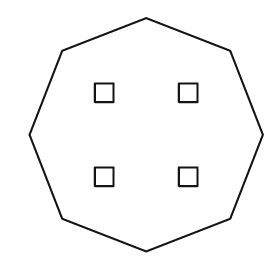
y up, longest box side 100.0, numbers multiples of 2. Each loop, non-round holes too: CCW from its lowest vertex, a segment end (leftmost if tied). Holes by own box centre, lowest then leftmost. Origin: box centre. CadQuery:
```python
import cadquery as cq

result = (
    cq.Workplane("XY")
    .moveTo(0.0, -50.0)
    .lineTo(36.0, -36.0)
    .lineTo(50.0, 0.0)
    .lineTo(36.0, 36.0)
    .lineTo(0.0, 50.0)
    .lineTo(-36.0, 36.0)
    .lineTo(-50.0, 0.0)
    .lineTo(-36.0, -36.0)
    .close()
    .moveTo(-22.0, -22.0)
    .lineTo(-14.0, -22.0)
    .lineTo(-14.0, -14.0)
    .lineTo(-22.0, -14.0)
    .close()
    .moveTo(14.0, -22.0)
    .lineTo(22.0, -22.0)
    .lineTo(22.0, -14.0)
    .lineTo(14.0, -14.0)
    .close()
    .moveTo(-22.0, 14.0)
    .lineTo(-14.0, 14.0)
    .lineTo(-14.0, 22.0)
    .lineTo(-22.0, 22.0)
    .close()
    .moveTo(14.0, 14.0)
    .lineTo(22.0, 14.0)
    .lineTo(22.0, 22.0)
    .lineTo(14.0, 22.0)
    .close()
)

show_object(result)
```